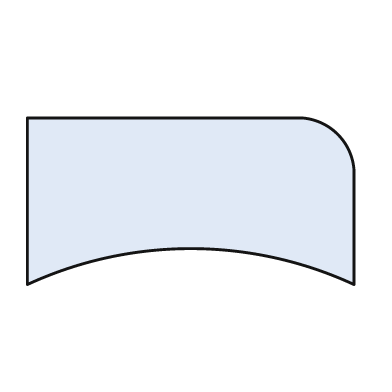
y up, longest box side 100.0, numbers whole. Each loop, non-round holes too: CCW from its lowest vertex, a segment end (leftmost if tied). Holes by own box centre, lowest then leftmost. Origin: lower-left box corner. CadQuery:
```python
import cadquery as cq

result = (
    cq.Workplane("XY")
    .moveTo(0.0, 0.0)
    .threePointArc((50.0, 11.0), (100.0, 0.0))
    .lineTo(100.0, 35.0)
    .threePointArc((95.0, 46.0), (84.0, 51.0))
    .lineTo(0.0, 51.0)
    .close()
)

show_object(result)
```